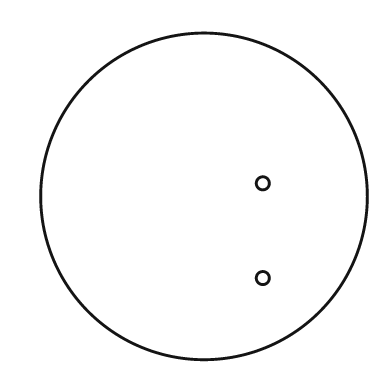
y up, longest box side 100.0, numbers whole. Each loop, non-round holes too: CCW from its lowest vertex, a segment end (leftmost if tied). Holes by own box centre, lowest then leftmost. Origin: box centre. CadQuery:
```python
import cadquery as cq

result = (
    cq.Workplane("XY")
    .moveTo(0.0, 0.0)
    .circle(50.0)
    .moveTo(18.0, -25.0)
    .circle(2.0)
    .moveTo(18.0, 4.0)
    .circle(2.0)
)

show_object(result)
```